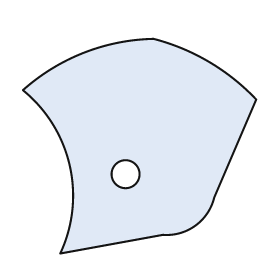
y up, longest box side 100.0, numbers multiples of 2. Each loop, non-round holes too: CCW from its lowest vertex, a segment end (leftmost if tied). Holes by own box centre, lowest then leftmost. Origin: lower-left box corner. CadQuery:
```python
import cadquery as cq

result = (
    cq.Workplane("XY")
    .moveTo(16.0, 0.0)
    .lineTo(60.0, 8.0)
    .threePointArc((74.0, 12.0), (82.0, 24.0))
    .lineTo(100.0, 66.0)
    .threePointArc((80.0, 82.0), (56.0, 92.0))
    .threePointArc((26.0, 86.0), (0.0, 70.0))
    .threePointArc((20.0, 38.0), (16.0, 0.0))
    .close()
    .moveTo(44.0, 34.0)
    .circle(6.0)
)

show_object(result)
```